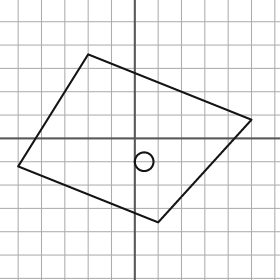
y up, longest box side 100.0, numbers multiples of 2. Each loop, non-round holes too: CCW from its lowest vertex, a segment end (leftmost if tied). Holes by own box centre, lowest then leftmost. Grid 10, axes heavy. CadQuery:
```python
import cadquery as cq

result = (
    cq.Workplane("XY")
    .moveTo(10.0, -36.0)
    .lineTo(50.0, 8.0)
    .lineTo(-20.0, 36.0)
    .lineTo(-50.0, -12.0)
    .close()
    .moveTo(4.0, -10.0)
    .circle(4.0)
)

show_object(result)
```